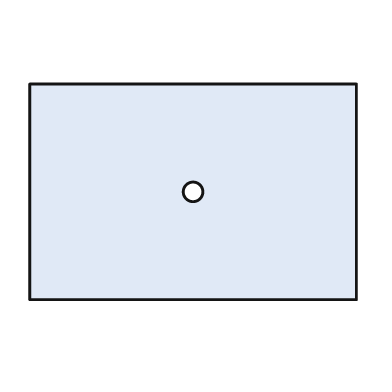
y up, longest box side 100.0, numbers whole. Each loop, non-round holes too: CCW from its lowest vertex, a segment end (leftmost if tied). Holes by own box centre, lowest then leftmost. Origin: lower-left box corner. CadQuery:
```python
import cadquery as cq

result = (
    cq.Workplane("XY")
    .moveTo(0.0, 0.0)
    .lineTo(100.0, 0.0)
    .lineTo(100.0, 66.0)
    .lineTo(0.0, 66.0)
    .close()
    .moveTo(50.0, 33.0)
    .circle(3.0)
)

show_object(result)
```